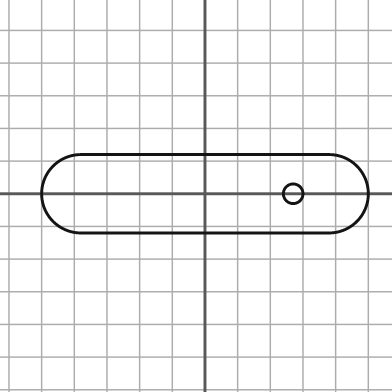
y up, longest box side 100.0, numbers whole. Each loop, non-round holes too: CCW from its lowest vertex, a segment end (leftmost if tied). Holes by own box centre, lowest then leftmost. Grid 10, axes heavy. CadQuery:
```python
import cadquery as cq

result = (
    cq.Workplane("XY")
    .moveTo(-38.0, -12.0)
    .lineTo(38.0, -12.0)
    .threePointArc((50.0, 0.0), (38.0, 12.0))
    .lineTo(-38.0, 12.0)
    .threePointArc((-50.0, 0.0), (-38.0, -12.0))
    .close()
    .moveTo(27.0, 0.0)
    .circle(3.0)
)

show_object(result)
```